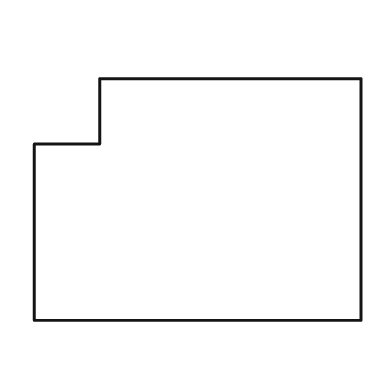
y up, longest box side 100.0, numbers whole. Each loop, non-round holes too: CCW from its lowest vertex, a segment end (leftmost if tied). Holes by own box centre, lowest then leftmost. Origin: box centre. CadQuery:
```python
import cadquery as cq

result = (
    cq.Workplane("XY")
    .moveTo(-50.0, -37.0)
    .lineTo(50.0, -37.0)
    .lineTo(50.0, 37.0)
    .lineTo(-30.0, 37.0)
    .lineTo(-30.0, 17.0)
    .lineTo(-50.0, 17.0)
    .close()
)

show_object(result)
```